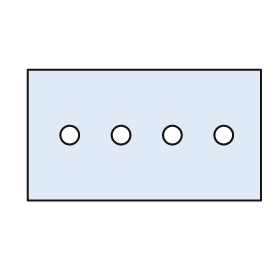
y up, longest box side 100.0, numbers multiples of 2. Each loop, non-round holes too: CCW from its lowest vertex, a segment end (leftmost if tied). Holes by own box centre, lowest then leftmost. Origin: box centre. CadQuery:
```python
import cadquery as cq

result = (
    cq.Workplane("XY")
    .moveTo(-50.0, -28.0)
    .lineTo(50.0, -28.0)
    .lineTo(50.0, 28.0)
    .lineTo(-50.0, 28.0)
    .close()
    .moveTo(-32.0, 0.0)
    .circle(4.0)
    .moveTo(-10.0, 0.0)
    .circle(4.0)
    .moveTo(12.0, 0.0)
    .circle(4.0)
    .moveTo(34.0, 0.0)
    .circle(4.0)
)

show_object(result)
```